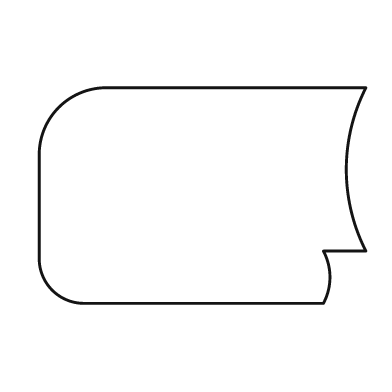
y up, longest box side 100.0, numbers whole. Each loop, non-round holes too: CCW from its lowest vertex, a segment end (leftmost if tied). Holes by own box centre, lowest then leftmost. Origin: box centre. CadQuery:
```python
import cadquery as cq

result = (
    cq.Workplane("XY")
    .moveTo(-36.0, -33.0)
    .lineTo(37.0, -33.0)
    .threePointArc((39.0, -25.0), (37.0, -17.0))
    .lineTo(50.0, -17.0)
    .threePointArc((44.0, 8.0), (50.0, 33.0))
    .lineTo(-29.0, 33.0)
    .threePointArc((-44.0, 27.0), (-50.0, 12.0))
    .lineTo(-50.0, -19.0)
    .threePointArc((-46.0, -29.0), (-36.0, -33.0))
    .close()
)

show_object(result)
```